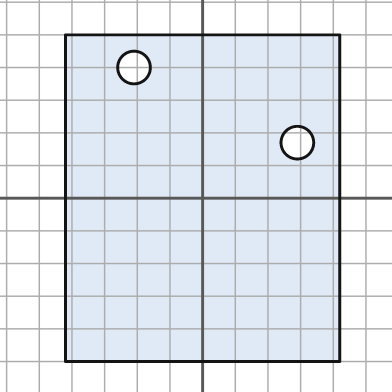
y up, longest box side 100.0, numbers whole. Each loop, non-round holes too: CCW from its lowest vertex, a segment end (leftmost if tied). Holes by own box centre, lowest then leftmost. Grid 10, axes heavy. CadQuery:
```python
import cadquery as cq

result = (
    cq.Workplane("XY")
    .moveTo(-42.0, -50.0)
    .lineTo(42.0, -50.0)
    .lineTo(42.0, 50.0)
    .lineTo(-42.0, 50.0)
    .close()
    .moveTo(29.0, 17.0)
    .circle(5.0)
    .moveTo(-21.0, 40.0)
    .circle(5.0)
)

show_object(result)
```